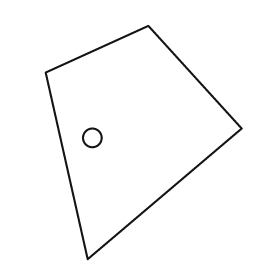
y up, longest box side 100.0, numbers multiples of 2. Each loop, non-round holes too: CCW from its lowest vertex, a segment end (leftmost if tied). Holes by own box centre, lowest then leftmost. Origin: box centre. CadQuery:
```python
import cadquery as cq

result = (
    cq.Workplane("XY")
    .moveTo(-24.0, -50.0)
    .lineTo(42.0, 6.0)
    .lineTo(2.0, 50.0)
    .lineTo(-42.0, 30.0)
    .close()
    .moveTo(-22.0, 2.0)
    .circle(4.0)
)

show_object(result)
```